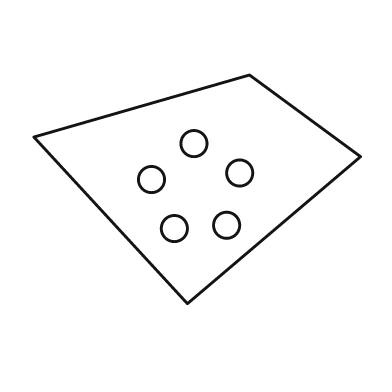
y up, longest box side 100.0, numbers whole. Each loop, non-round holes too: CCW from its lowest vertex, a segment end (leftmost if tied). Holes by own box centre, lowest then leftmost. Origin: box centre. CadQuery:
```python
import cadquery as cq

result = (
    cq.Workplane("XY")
    .moveTo(-3.0, -35.0)
    .lineTo(50.0, 10.0)
    .lineTo(16.0, 35.0)
    .lineTo(-50.0, 16.0)
    .close()
    .moveTo(-7.0, -12.0)
    .circle(4.0)
    .moveTo(9.0, -11.0)
    .circle(4.0)
    .moveTo(-14.0, 3.0)
    .circle(4.0)
    .moveTo(13.0, 5.0)
    .circle(4.0)
    .moveTo(-1.0, 14.0)
    .circle(4.0)
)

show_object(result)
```